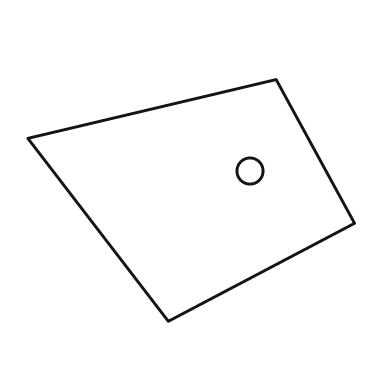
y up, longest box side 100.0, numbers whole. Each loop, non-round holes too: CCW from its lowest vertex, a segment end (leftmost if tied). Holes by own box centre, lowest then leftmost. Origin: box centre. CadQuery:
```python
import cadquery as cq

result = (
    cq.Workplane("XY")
    .moveTo(-7.0, -37.0)
    .lineTo(50.0, -7.0)
    .lineTo(26.0, 37.0)
    .lineTo(-50.0, 19.0)
    .close()
    .moveTo(18.0, 9.0)
    .circle(4.0)
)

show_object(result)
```